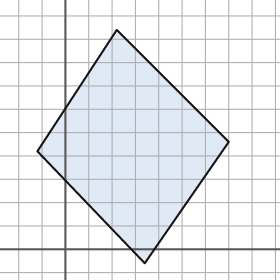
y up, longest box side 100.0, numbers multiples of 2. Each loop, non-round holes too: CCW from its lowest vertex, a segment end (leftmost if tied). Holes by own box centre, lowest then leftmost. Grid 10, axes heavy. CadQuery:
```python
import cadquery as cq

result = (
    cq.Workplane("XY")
    .moveTo(34.0, -6.0)
    .lineTo(70.0, 46.0)
    .lineTo(22.0, 94.0)
    .lineTo(-12.0, 42.0)
    .close()
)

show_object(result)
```